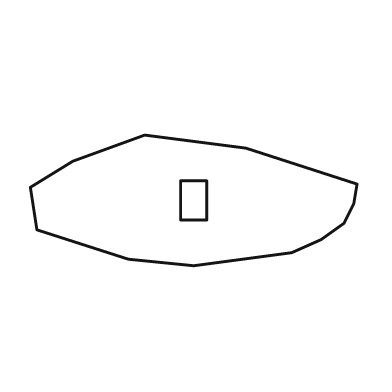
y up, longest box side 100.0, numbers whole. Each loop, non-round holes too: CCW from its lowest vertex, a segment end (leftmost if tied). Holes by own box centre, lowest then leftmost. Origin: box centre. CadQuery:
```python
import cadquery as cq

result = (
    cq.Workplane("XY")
    .moveTo(0.0, -20.0)
    .lineTo(30.0, -16.0)
    .lineTo(39.0, -12.0)
    .lineTo(46.0, -7.0)
    .lineTo(49.0, -1.0)
    .lineTo(50.0, 5.0)
    .lineTo(16.0, 16.0)
    .lineTo(-15.0, 20.0)
    .lineTo(-37.0, 12.0)
    .lineTo(-50.0, 4.0)
    .lineTo(-48.0, -9.0)
    .lineTo(-20.0, -18.0)
    .close()
    .moveTo(-4.0, -6.0)
    .lineTo(4.0, -6.0)
    .lineTo(4.0, 6.0)
    .lineTo(-4.0, 6.0)
    .close()
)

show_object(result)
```